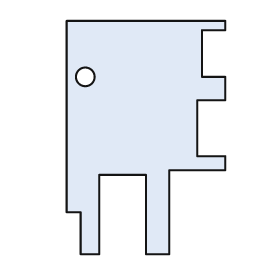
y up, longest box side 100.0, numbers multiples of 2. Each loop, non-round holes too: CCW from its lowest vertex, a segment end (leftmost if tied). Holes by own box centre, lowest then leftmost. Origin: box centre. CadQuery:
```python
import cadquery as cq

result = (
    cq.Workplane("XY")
    .moveTo(-28.0, -50.0)
    .lineTo(-20.0, -50.0)
    .lineTo(-20.0, -16.0)
    .lineTo(0.0, -16.0)
    .lineTo(0.0, -50.0)
    .lineTo(10.0, -50.0)
    .lineTo(10.0, -14.0)
    .lineTo(34.0, -14.0)
    .lineTo(34.0, -8.0)
    .lineTo(22.0, -8.0)
    .lineTo(22.0, 16.0)
    .lineTo(34.0, 16.0)
    .lineTo(34.0, 26.0)
    .lineTo(24.0, 26.0)
    .lineTo(24.0, 46.0)
    .lineTo(34.0, 46.0)
    .lineTo(34.0, 50.0)
    .lineTo(-34.0, 50.0)
    .lineTo(-34.0, -32.0)
    .lineTo(-28.0, -32.0)
    .close()
    .moveTo(-26.0, 26.0)
    .circle(4.0)
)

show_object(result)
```